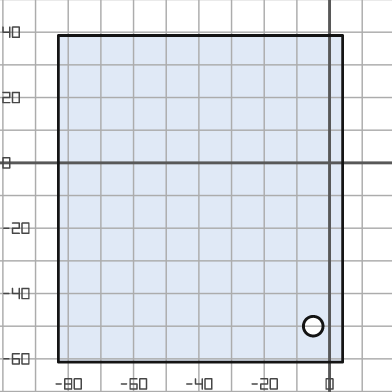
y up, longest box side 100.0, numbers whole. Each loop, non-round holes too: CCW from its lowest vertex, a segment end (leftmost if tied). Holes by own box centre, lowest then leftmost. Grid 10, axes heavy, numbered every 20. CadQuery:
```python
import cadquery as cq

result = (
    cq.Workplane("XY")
    .moveTo(-83.0, -61.0)
    .lineTo(4.0, -61.0)
    .lineTo(4.0, 39.0)
    .lineTo(-83.0, 39.0)
    .close()
    .moveTo(-5.0, -50.0)
    .circle(3.0)
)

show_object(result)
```